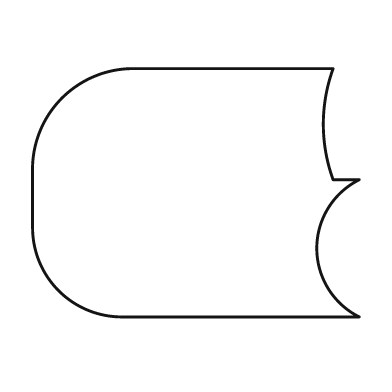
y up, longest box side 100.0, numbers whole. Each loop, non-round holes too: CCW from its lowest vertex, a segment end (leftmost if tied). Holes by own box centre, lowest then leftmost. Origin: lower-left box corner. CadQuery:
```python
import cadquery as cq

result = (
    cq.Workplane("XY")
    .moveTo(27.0, 0.0)
    .lineTo(100.0, 0.0)
    .threePointArc((87.0, 21.0), (100.0, 42.0))
    .lineTo(92.0, 42.0)
    .threePointArc((89.0, 59.0), (92.0, 76.0))
    .lineTo(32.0, 76.0)
    .threePointArc((9.0, 67.0), (0.0, 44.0))
    .lineTo(0.0, 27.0)
    .threePointArc((8.0, 8.0), (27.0, 0.0))
    .close()
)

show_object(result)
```